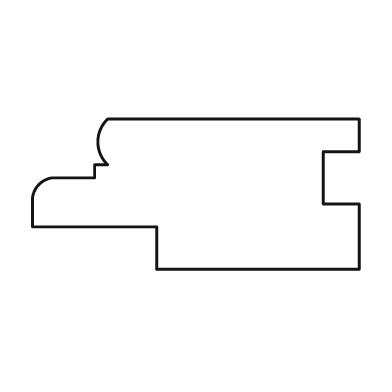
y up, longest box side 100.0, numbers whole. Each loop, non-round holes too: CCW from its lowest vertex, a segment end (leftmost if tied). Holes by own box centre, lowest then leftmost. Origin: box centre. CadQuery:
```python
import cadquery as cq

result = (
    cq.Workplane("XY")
    .moveTo(-12.0, -23.0)
    .lineTo(50.0, -23.0)
    .lineTo(50.0, -3.0)
    .lineTo(39.0, -3.0)
    .lineTo(39.0, 13.0)
    .lineTo(50.0, 13.0)
    .lineTo(50.0, 23.0)
    .lineTo(-27.0, 23.0)
    .threePointArc((-30.0, 16.0), (-27.0, 9.0))
    .lineTo(-31.0, 9.0)
    .lineTo(-31.0, 5.0)
    .lineTo(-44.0, 5.0)
    .threePointArc((-48.0, 3.0), (-50.0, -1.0))
    .lineTo(-50.0, -10.0)
    .lineTo(-12.0, -10.0)
    .close()
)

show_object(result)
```